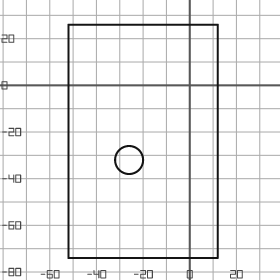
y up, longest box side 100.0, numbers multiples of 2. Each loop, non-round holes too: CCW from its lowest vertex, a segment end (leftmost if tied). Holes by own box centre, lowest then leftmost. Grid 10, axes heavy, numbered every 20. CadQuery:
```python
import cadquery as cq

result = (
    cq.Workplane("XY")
    .moveTo(-52.0, -74.0)
    .lineTo(12.0, -74.0)
    .lineTo(12.0, 26.0)
    .lineTo(-52.0, 26.0)
    .close()
    .moveTo(-26.0, -32.0)
    .circle(6.0)
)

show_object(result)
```